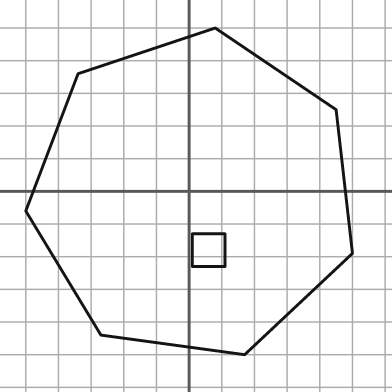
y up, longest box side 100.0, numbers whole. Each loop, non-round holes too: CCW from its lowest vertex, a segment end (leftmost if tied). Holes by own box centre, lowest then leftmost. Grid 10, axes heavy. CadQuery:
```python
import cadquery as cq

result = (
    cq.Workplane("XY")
    .moveTo(17.0, -50.0)
    .lineTo(50.0, -19.0)
    .lineTo(45.0, 25.0)
    .lineTo(8.0, 50.0)
    .lineTo(-34.0, 36.0)
    .lineTo(-50.0, -6.0)
    .lineTo(-27.0, -44.0)
    .close()
    .moveTo(1.0, -23.0)
    .lineTo(11.0, -23.0)
    .lineTo(11.0, -13.0)
    .lineTo(1.0, -13.0)
    .close()
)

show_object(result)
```